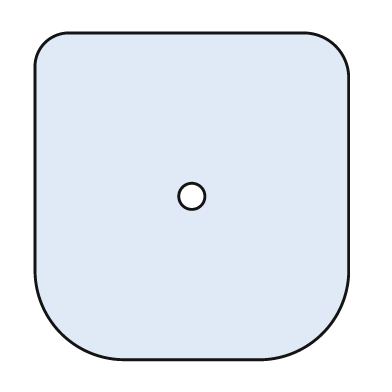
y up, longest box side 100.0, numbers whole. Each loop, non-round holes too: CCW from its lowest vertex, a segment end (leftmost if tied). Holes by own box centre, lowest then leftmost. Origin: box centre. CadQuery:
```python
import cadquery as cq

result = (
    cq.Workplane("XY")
    .moveTo(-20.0, -50.0)
    .lineTo(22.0, -50.0)
    .threePointArc((40.0, -42.0), (48.0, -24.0))
    .lineTo(48.0, 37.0)
    .threePointArc((44.0, 46.0), (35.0, 50.0))
    .lineTo(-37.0, 50.0)
    .threePointArc((-45.0, 47.0), (-48.0, 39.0))
    .lineTo(-48.0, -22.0)
    .threePointArc((-40.0, -42.0), (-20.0, -50.0))
    .close()
    .moveTo(0.0, 0.0)
    .circle(4.0)
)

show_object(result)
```